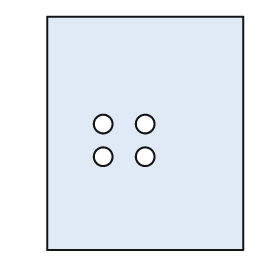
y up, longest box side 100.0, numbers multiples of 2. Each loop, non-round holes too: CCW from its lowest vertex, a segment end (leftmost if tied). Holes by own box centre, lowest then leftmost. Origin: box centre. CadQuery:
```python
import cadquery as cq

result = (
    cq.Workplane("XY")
    .moveTo(-42.0, -50.0)
    .lineTo(42.0, -50.0)
    .lineTo(42.0, 50.0)
    .lineTo(-42.0, 50.0)
    .close()
    .moveTo(-18.0, -10.0)
    .circle(4.0)
    .moveTo(0.0, -10.0)
    .circle(4.0)
    .moveTo(-18.0, 4.0)
    .circle(4.0)
    .moveTo(0.0, 4.0)
    .circle(4.0)
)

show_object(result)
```